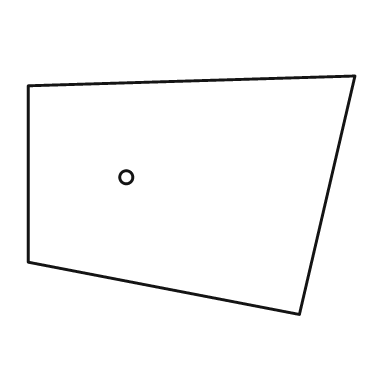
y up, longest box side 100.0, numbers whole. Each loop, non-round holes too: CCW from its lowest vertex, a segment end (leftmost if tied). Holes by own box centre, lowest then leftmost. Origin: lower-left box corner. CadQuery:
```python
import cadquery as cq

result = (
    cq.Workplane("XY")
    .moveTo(83.0, 0.0)
    .lineTo(100.0, 73.0)
    .lineTo(0.0, 70.0)
    .lineTo(0.0, 16.0)
    .close()
    .moveTo(30.0, 42.0)
    .circle(2.0)
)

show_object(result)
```